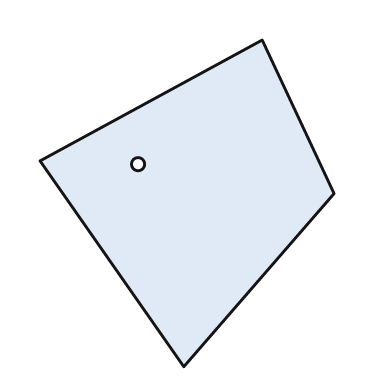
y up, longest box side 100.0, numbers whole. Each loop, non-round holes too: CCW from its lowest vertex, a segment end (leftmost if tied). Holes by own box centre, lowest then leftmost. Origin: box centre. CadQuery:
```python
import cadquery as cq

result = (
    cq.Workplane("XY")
    .moveTo(-1.0, -50.0)
    .lineTo(45.0, 3.0)
    .lineTo(23.0, 50.0)
    .lineTo(-45.0, 13.0)
    .close()
    .moveTo(-15.0, 12.0)
    .circle(2.0)
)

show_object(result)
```